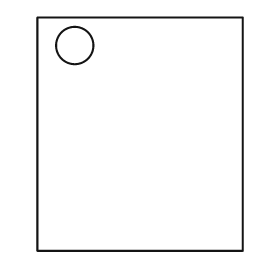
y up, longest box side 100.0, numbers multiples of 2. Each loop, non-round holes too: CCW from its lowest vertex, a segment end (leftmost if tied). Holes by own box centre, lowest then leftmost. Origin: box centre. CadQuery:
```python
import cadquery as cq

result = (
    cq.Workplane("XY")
    .moveTo(-44.0, -50.0)
    .lineTo(44.0, -50.0)
    .lineTo(44.0, 50.0)
    .lineTo(-44.0, 50.0)
    .close()
    .moveTo(-28.0, 38.0)
    .circle(8.0)
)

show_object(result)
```